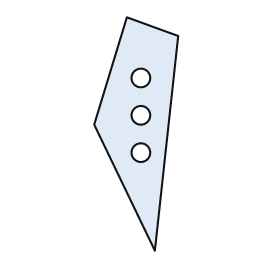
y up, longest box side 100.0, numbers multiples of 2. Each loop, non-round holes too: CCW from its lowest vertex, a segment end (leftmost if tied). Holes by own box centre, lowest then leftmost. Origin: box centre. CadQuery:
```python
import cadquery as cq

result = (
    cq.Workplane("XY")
    .moveTo(8.0, -50.0)
    .lineTo(18.0, 42.0)
    .lineTo(-4.0, 50.0)
    .lineTo(-18.0, 4.0)
    .close()
    .moveTo(2.0, -8.0)
    .circle(4.0)
    .moveTo(2.0, 8.0)
    .circle(4.0)
    .moveTo(2.0, 24.0)
    .circle(4.0)
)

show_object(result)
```